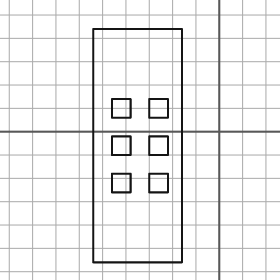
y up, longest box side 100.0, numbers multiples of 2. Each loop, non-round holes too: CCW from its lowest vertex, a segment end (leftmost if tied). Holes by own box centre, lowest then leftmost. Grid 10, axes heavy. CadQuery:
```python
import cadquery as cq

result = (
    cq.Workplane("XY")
    .moveTo(-54.0, -56.0)
    .lineTo(-16.0, -56.0)
    .lineTo(-16.0, 44.0)
    .lineTo(-54.0, 44.0)
    .close()
    .moveTo(-46.0, -26.0)
    .lineTo(-38.0, -26.0)
    .lineTo(-38.0, -18.0)
    .lineTo(-46.0, -18.0)
    .close()
    .moveTo(-30.0, -26.0)
    .lineTo(-22.0, -26.0)
    .lineTo(-22.0, -18.0)
    .lineTo(-30.0, -18.0)
    .close()
    .moveTo(-46.0, -10.0)
    .lineTo(-38.0, -10.0)
    .lineTo(-38.0, -2.0)
    .lineTo(-46.0, -2.0)
    .close()
    .moveTo(-30.0, -10.0)
    .lineTo(-22.0, -10.0)
    .lineTo(-22.0, -2.0)
    .lineTo(-30.0, -2.0)
    .close()
    .moveTo(-46.0, 6.0)
    .lineTo(-38.0, 6.0)
    .lineTo(-38.0, 14.0)
    .lineTo(-46.0, 14.0)
    .close()
    .moveTo(-30.0, 6.0)
    .lineTo(-22.0, 6.0)
    .lineTo(-22.0, 14.0)
    .lineTo(-30.0, 14.0)
    .close()
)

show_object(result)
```